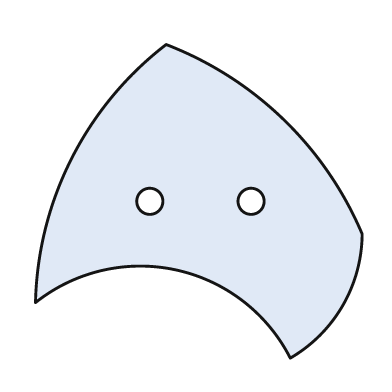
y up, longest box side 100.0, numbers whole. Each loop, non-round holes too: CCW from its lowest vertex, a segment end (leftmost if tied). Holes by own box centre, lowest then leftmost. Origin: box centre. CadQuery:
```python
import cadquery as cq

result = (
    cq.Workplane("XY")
    .moveTo(28.0, -48.0)
    .threePointArc((44.0, -32.0), (50.0, -10.0))
    .threePointArc((26.0, 25.0), (-10.0, 48.0))
    .threePointArc((-39.0, 13.0), (-50.0, -31.0))
    .threePointArc((-7.0, -21.0), (28.0, -48.0))
    .close()
    .moveTo(-15.0, 0.0)
    .circle(4.0)
    .moveTo(16.0, 0.0)
    .circle(4.0)
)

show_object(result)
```